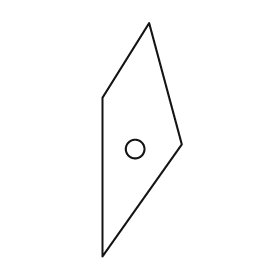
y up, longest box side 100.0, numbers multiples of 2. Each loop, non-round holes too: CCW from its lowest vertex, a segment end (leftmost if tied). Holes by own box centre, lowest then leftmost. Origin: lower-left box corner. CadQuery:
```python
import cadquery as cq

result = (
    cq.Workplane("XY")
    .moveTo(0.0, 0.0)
    .lineTo(34.0, 48.0)
    .lineTo(20.0, 100.0)
    .lineTo(0.0, 68.0)
    .close()
    .moveTo(14.0, 46.0)
    .circle(4.0)
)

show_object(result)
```